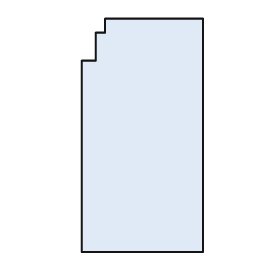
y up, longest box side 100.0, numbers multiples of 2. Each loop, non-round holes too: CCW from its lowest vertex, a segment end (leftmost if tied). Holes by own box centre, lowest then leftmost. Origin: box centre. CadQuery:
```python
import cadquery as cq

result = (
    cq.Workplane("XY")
    .moveTo(-26.0, -50.0)
    .lineTo(26.0, -50.0)
    .lineTo(26.0, 50.0)
    .lineTo(-16.0, 50.0)
    .lineTo(-16.0, 44.0)
    .lineTo(-20.0, 44.0)
    .lineTo(-20.0, 32.0)
    .lineTo(-26.0, 32.0)
    .close()
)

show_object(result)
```